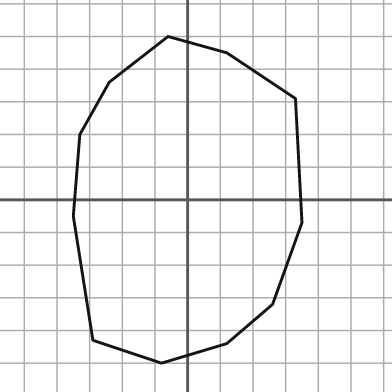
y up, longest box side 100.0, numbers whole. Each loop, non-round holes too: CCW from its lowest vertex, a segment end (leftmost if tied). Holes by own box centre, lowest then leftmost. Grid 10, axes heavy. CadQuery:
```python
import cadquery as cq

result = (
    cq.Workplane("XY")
    .moveTo(-8.0, -50.0)
    .lineTo(12.0, -44.0)
    .lineTo(26.0, -32.0)
    .lineTo(35.0, -7.0)
    .lineTo(33.0, 31.0)
    .lineTo(12.0, 45.0)
    .lineTo(-6.0, 50.0)
    .lineTo(-24.0, 36.0)
    .lineTo(-33.0, 20.0)
    .lineTo(-35.0, -5.0)
    .lineTo(-29.0, -43.0)
    .close()
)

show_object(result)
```